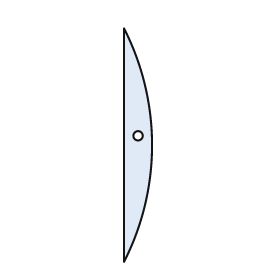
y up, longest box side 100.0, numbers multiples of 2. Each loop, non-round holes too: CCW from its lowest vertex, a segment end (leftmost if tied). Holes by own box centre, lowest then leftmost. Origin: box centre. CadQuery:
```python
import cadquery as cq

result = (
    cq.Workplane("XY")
    .moveTo(-6.0, -50.0)
    .threePointArc((6.0, 0.0), (-6.0, 50.0))
    .close()
    .moveTo(0.0, 4.0)
    .circle(2.0)
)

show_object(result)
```